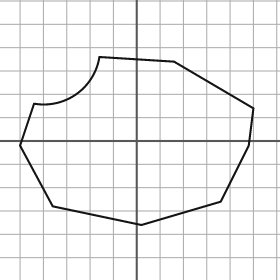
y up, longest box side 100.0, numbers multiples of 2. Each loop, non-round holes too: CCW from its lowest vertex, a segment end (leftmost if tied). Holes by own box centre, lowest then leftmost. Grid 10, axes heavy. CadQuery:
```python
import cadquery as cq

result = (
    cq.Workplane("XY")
    .moveTo(2.0, -36.0)
    .lineTo(36.0, -26.0)
    .lineTo(48.0, -2.0)
    .lineTo(50.0, 14.0)
    .lineTo(16.0, 34.0)
    .lineTo(-16.0, 36.0)
    .threePointArc((-26.0, 20.0), (-44.0, 16.0))
    .lineTo(-50.0, -2.0)
    .lineTo(-36.0, -28.0)
    .close()
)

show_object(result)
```